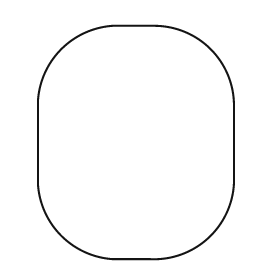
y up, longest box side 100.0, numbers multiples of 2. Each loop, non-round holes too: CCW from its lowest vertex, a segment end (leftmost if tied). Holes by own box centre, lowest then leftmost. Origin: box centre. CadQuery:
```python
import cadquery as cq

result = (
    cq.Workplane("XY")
    .moveTo(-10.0, -50.0)
    .lineTo(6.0, -50.0)
    .threePointArc((32.0, -40.0), (42.0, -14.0))
    .lineTo(42.0, 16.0)
    .threePointArc((32.0, 40.0), (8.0, 50.0))
    .lineTo(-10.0, 50.0)
    .threePointArc((-32.0, 40.0), (-42.0, 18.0))
    .lineTo(-42.0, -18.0)
    .threePointArc((-32.0, -40.0), (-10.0, -50.0))
    .close()
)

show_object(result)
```